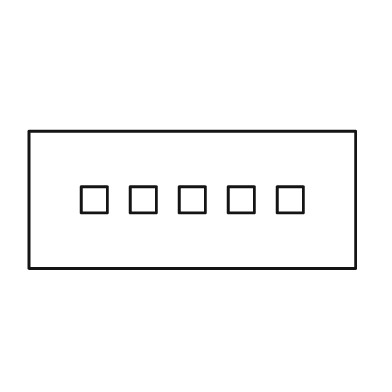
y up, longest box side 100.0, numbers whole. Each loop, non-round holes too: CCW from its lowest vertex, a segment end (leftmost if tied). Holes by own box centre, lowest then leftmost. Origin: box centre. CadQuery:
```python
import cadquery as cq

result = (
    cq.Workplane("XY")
    .moveTo(-50.0, -21.0)
    .lineTo(50.0, -21.0)
    .lineTo(50.0, 21.0)
    .lineTo(-50.0, 21.0)
    .close()
    .moveTo(-34.0, -4.0)
    .lineTo(-26.0, -4.0)
    .lineTo(-26.0, 4.0)
    .lineTo(-34.0, 4.0)
    .close()
    .moveTo(-19.0, -4.0)
    .lineTo(-11.0, -4.0)
    .lineTo(-11.0, 4.0)
    .lineTo(-19.0, 4.0)
    .close()
    .moveTo(-4.0, -4.0)
    .lineTo(4.0, -4.0)
    .lineTo(4.0, 4.0)
    .lineTo(-4.0, 4.0)
    .close()
    .moveTo(11.0, -4.0)
    .lineTo(19.0, -4.0)
    .lineTo(19.0, 4.0)
    .lineTo(11.0, 4.0)
    .close()
    .moveTo(26.0, -4.0)
    .lineTo(34.0, -4.0)
    .lineTo(34.0, 4.0)
    .lineTo(26.0, 4.0)
    .close()
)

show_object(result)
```